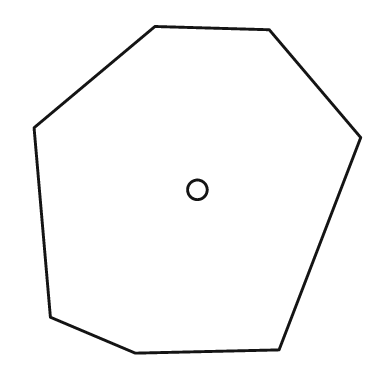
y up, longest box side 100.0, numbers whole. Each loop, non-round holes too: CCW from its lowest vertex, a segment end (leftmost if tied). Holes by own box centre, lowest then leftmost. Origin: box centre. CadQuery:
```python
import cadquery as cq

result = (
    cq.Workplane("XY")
    .moveTo(-19.0, -50.0)
    .lineTo(25.0, -49.0)
    .lineTo(50.0, 16.0)
    .lineTo(22.0, 49.0)
    .lineTo(-13.0, 50.0)
    .lineTo(-50.0, 19.0)
    .lineTo(-45.0, -39.0)
    .close()
    .moveTo(0.0, 0.0)
    .circle(3.0)
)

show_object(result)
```